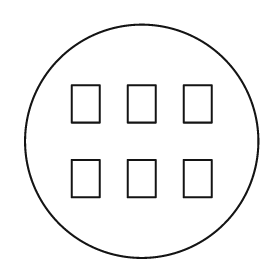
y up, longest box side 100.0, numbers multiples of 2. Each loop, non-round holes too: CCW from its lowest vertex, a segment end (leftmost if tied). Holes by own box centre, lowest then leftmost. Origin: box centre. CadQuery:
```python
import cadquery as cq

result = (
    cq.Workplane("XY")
    .moveTo(0.0, 0.0)
    .circle(50.0)
    .moveTo(-30.0, -24.0)
    .lineTo(-18.0, -24.0)
    .lineTo(-18.0, -8.0)
    .lineTo(-30.0, -8.0)
    .close()
    .moveTo(-6.0, -24.0)
    .lineTo(6.0, -24.0)
    .lineTo(6.0, -8.0)
    .lineTo(-6.0, -8.0)
    .close()
    .moveTo(18.0, -24.0)
    .lineTo(30.0, -24.0)
    .lineTo(30.0, -8.0)
    .lineTo(18.0, -8.0)
    .close()
    .moveTo(-30.0, 8.0)
    .lineTo(-18.0, 8.0)
    .lineTo(-18.0, 24.0)
    .lineTo(-30.0, 24.0)
    .close()
    .moveTo(-6.0, 8.0)
    .lineTo(6.0, 8.0)
    .lineTo(6.0, 24.0)
    .lineTo(-6.0, 24.0)
    .close()
    .moveTo(18.0, 8.0)
    .lineTo(30.0, 8.0)
    .lineTo(30.0, 24.0)
    .lineTo(18.0, 24.0)
    .close()
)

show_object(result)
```